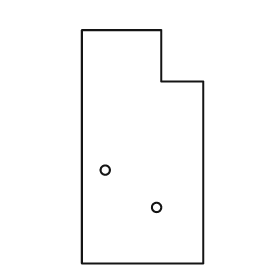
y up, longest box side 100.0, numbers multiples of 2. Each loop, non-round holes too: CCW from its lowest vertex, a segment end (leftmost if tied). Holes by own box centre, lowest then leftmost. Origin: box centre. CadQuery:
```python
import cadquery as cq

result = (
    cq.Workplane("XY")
    .moveTo(-26.0, -50.0)
    .lineTo(26.0, -50.0)
    .lineTo(26.0, 28.0)
    .lineTo(8.0, 28.0)
    .lineTo(8.0, 50.0)
    .lineTo(-26.0, 50.0)
    .close()
    .moveTo(6.0, -26.0)
    .circle(2.0)
    .moveTo(-16.0, -10.0)
    .circle(2.0)
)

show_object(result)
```